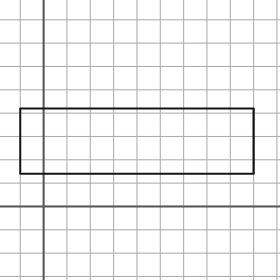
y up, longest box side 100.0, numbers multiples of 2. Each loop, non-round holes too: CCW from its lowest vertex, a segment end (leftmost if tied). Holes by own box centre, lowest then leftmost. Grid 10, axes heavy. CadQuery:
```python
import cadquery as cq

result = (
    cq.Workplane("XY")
    .moveTo(-10.0, 14.0)
    .lineTo(90.0, 14.0)
    .lineTo(90.0, 42.0)
    .lineTo(-10.0, 42.0)
    .close()
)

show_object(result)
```